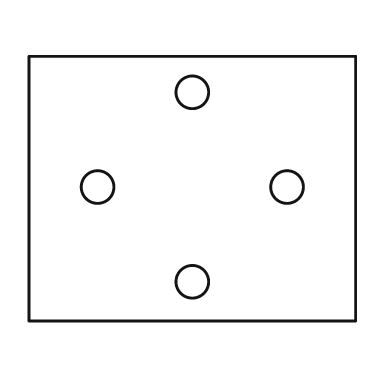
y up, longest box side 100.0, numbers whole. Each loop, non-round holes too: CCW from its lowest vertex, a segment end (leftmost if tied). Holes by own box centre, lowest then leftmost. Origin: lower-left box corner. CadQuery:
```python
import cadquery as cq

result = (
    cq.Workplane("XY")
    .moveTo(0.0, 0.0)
    .lineTo(100.0, 0.0)
    .lineTo(100.0, 81.0)
    .lineTo(0.0, 81.0)
    .close()
    .moveTo(50.0, 12.0)
    .circle(5.0)
    .moveTo(21.0, 41.0)
    .circle(5.0)
    .moveTo(79.0, 41.0)
    .circle(5.0)
    .moveTo(50.0, 70.0)
    .circle(5.0)
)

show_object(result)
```